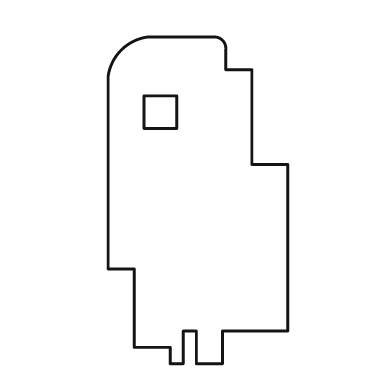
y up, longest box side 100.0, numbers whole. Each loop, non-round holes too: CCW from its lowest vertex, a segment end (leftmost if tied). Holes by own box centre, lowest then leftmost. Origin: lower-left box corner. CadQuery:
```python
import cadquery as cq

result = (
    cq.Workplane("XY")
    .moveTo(19.0, 0.0)
    .lineTo(23.0, 0.0)
    .lineTo(23.0, 10.0)
    .lineTo(27.0, 10.0)
    .lineTo(27.0, 0.0)
    .lineTo(35.0, 0.0)
    .lineTo(35.0, 10.0)
    .lineTo(55.0, 10.0)
    .lineTo(55.0, 61.0)
    .lineTo(44.0, 61.0)
    .lineTo(44.0, 90.0)
    .lineTo(36.0, 90.0)
    .lineTo(36.0, 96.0)
    .threePointArc((35.0, 99.0), (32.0, 100.0))
    .lineTo(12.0, 100.0)
    .threePointArc((4.0, 96.0), (0.0, 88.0))
    .lineTo(0.0, 29.0)
    .lineTo(8.0, 29.0)
    .lineTo(8.0, 5.0)
    .lineTo(19.0, 5.0)
    .close()
    .moveTo(11.0, 72.0)
    .lineTo(21.0, 72.0)
    .lineTo(21.0, 82.0)
    .lineTo(11.0, 82.0)
    .close()
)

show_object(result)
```